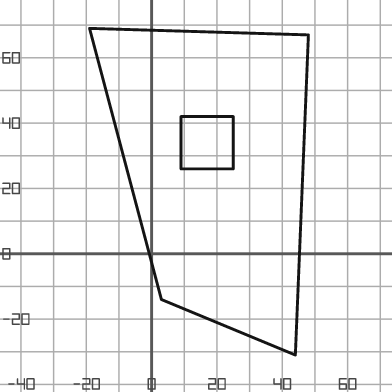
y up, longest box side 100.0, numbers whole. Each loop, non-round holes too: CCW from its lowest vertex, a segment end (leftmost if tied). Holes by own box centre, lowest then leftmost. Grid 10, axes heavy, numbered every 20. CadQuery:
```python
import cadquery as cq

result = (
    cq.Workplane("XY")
    .moveTo(44.0, -31.0)
    .lineTo(48.0, 67.0)
    .lineTo(-19.0, 69.0)
    .lineTo(3.0, -14.0)
    .close()
    .moveTo(9.0, 26.0)
    .lineTo(25.0, 26.0)
    .lineTo(25.0, 42.0)
    .lineTo(9.0, 42.0)
    .close()
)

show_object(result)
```